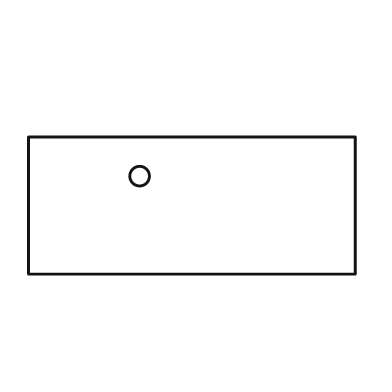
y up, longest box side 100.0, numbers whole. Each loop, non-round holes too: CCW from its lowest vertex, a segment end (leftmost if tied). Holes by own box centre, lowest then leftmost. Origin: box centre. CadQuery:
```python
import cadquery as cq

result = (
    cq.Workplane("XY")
    .moveTo(-50.0, -21.0)
    .lineTo(50.0, -21.0)
    .lineTo(50.0, 21.0)
    .lineTo(-50.0, 21.0)
    .close()
    .moveTo(-16.0, 9.0)
    .circle(3.0)
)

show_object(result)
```